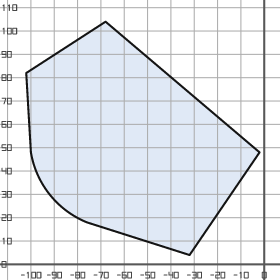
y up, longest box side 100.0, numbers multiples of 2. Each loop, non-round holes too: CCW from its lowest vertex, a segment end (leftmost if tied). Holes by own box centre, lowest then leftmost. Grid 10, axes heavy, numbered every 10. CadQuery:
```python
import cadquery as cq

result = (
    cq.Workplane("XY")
    .moveTo(-32.0, 4.0)
    .lineTo(-2.0, 48.0)
    .lineTo(-68.0, 104.0)
    .lineTo(-102.0, 82.0)
    .lineTo(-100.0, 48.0)
    .threePointArc((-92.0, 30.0), (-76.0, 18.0))
    .close()
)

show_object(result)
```